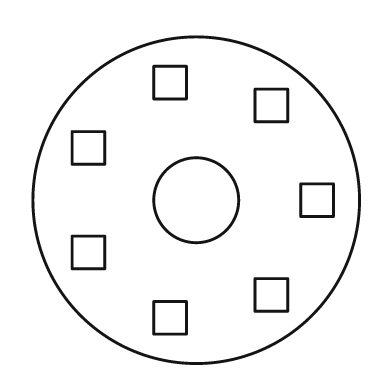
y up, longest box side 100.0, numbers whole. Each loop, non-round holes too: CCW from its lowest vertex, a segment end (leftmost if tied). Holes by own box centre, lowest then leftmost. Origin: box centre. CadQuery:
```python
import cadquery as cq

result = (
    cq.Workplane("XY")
    .moveTo(0.0, 0.0)
    .circle(50.0)
    .moveTo(-13.0, -41.0)
    .lineTo(-3.0, -41.0)
    .lineTo(-3.0, -31.0)
    .lineTo(-13.0, -31.0)
    .close()
    .moveTo(18.0, -34.0)
    .lineTo(28.0, -34.0)
    .lineTo(28.0, -24.0)
    .lineTo(18.0, -24.0)
    .close()
    .moveTo(-38.0, -21.0)
    .lineTo(-28.0, -21.0)
    .lineTo(-28.0, -11.0)
    .lineTo(-38.0, -11.0)
    .close()
    .moveTo(0.0, 0.0)
    .circle(13.0)
    .moveTo(32.0, -5.0)
    .lineTo(42.0, -5.0)
    .lineTo(42.0, 5.0)
    .lineTo(32.0, 5.0)
    .close()
    .moveTo(-38.0, 11.0)
    .lineTo(-28.0, 11.0)
    .lineTo(-28.0, 21.0)
    .lineTo(-38.0, 21.0)
    .close()
    .moveTo(18.0, 24.0)
    .lineTo(28.0, 24.0)
    .lineTo(28.0, 34.0)
    .lineTo(18.0, 34.0)
    .close()
    .moveTo(-13.0, 31.0)
    .lineTo(-3.0, 31.0)
    .lineTo(-3.0, 41.0)
    .lineTo(-13.0, 41.0)
    .close()
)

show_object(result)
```